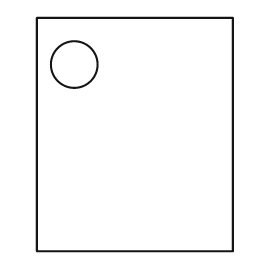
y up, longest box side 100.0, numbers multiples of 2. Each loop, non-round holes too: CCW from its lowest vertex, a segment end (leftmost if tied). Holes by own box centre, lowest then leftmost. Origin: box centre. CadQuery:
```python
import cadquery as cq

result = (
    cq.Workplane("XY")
    .moveTo(-42.0, -50.0)
    .lineTo(42.0, -50.0)
    .lineTo(42.0, 50.0)
    .lineTo(-42.0, 50.0)
    .close()
    .moveTo(-26.0, 30.0)
    .circle(10.0)
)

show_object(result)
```